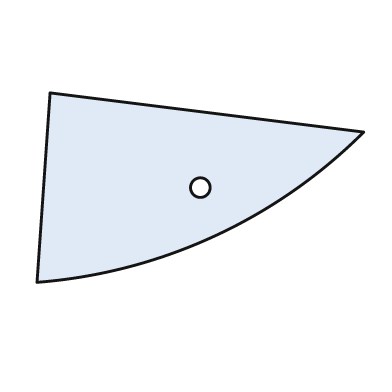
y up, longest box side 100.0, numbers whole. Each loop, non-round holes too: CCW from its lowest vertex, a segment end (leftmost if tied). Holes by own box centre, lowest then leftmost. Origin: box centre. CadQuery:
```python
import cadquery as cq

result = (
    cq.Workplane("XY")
    .moveTo(-50.0, -29.0)
    .threePointArc((4.0, -15.0), (50.0, 17.0))
    .lineTo(-46.0, 29.0)
    .close()
    .moveTo(0.0, 0.0)
    .circle(3.0)
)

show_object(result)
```